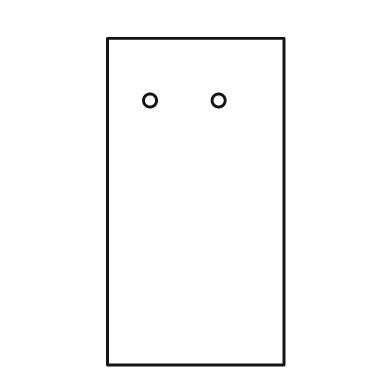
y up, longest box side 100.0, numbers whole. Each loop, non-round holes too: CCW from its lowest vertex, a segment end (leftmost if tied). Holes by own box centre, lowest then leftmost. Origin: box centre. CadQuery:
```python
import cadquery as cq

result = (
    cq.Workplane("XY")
    .moveTo(-27.0, -50.0)
    .lineTo(27.0, -50.0)
    .lineTo(27.0, 50.0)
    .lineTo(-27.0, 50.0)
    .close()
    .moveTo(-14.0, 31.0)
    .circle(2.0)
    .moveTo(7.0, 31.0)
    .circle(2.0)
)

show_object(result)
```